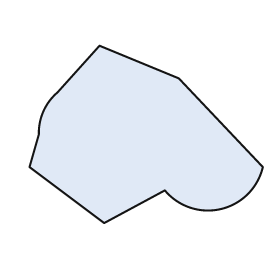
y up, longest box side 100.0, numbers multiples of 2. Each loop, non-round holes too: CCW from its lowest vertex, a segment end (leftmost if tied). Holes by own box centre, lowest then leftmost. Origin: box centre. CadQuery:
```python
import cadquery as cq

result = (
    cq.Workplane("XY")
    .moveTo(-18.0, -38.0)
    .lineTo(8.0, -24.0)
    .threePointArc((32.0, -32.0), (50.0, -14.0))
    .lineTo(14.0, 24.0)
    .lineTo(-20.0, 38.0)
    .lineTo(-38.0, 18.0)
    .threePointArc((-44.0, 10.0), (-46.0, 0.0))
    .lineTo(-50.0, -14.0)
    .close()
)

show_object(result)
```